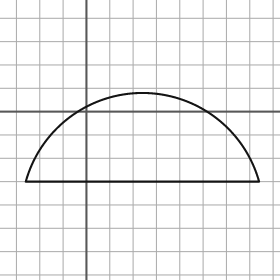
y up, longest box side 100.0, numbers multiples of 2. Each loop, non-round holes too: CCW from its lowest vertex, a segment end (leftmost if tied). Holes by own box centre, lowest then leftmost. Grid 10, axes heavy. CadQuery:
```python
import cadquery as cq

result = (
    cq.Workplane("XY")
    .moveTo(-26.0, -30.0)
    .lineTo(74.0, -30.0)
    .threePointArc((24.0, 8.0), (-26.0, -30.0))
    .close()
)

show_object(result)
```